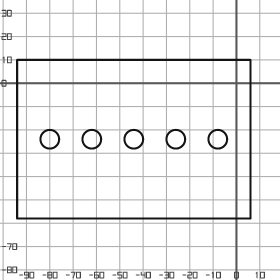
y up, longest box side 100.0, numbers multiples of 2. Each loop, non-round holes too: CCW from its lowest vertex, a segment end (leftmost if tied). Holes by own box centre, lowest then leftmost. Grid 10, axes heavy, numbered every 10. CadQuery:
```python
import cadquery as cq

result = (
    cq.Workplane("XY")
    .moveTo(-94.0, -58.0)
    .lineTo(6.0, -58.0)
    .lineTo(6.0, 10.0)
    .lineTo(-94.0, 10.0)
    .close()
    .moveTo(-80.0, -24.0)
    .circle(4.0)
    .moveTo(-62.0, -24.0)
    .circle(4.0)
    .moveTo(-44.0, -24.0)
    .circle(4.0)
    .moveTo(-26.0, -24.0)
    .circle(4.0)
    .moveTo(-8.0, -24.0)
    .circle(4.0)
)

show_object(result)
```